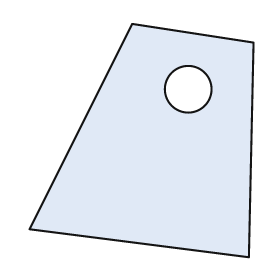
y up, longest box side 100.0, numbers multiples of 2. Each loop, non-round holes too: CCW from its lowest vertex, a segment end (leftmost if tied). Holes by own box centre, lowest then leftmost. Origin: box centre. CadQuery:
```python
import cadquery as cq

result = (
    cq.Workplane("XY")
    .moveTo(46.0, -50.0)
    .lineTo(48.0, 42.0)
    .lineTo(-4.0, 50.0)
    .lineTo(-48.0, -38.0)
    .close()
    .moveTo(20.0, 22.0)
    .circle(10.0)
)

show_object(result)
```